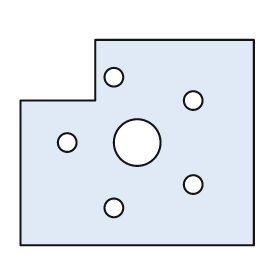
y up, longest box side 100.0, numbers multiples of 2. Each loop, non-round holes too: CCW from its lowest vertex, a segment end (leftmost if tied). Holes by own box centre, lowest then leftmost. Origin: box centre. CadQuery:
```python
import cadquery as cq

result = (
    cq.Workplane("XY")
    .moveTo(-50.0, -44.0)
    .lineTo(50.0, -44.0)
    .lineTo(50.0, 44.0)
    .lineTo(-18.0, 44.0)
    .lineTo(-18.0, 18.0)
    .lineTo(-50.0, 18.0)
    .close()
    .moveTo(-10.0, -28.0)
    .circle(4.0)
    .moveTo(24.0, -18.0)
    .circle(4.0)
    .moveTo(-30.0, 0.0)
    .circle(4.0)
    .moveTo(0.0, 0.0)
    .circle(10.0)
    .moveTo(24.0, 18.0)
    .circle(4.0)
    .moveTo(-10.0, 28.0)
    .circle(4.0)
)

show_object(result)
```